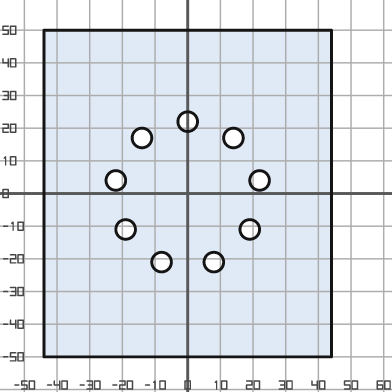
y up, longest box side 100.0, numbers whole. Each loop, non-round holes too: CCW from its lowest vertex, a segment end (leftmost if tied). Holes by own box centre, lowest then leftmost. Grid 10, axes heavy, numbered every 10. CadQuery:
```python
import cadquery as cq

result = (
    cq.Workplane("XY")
    .moveTo(-44.0, -50.0)
    .lineTo(44.0, -50.0)
    .lineTo(44.0, 50.0)
    .lineTo(-44.0, 50.0)
    .close()
    .moveTo(-8.0, -21.0)
    .circle(3.0)
    .moveTo(8.0, -21.0)
    .circle(3.0)
    .moveTo(-19.0, -11.0)
    .circle(3.0)
    .moveTo(19.0, -11.0)
    .circle(3.0)
    .moveTo(-22.0, 4.0)
    .circle(3.0)
    .moveTo(22.0, 4.0)
    .circle(3.0)
    .moveTo(-14.0, 17.0)
    .circle(3.0)
    .moveTo(14.0, 17.0)
    .circle(3.0)
    .moveTo(0.0, 22.0)
    .circle(3.0)
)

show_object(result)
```